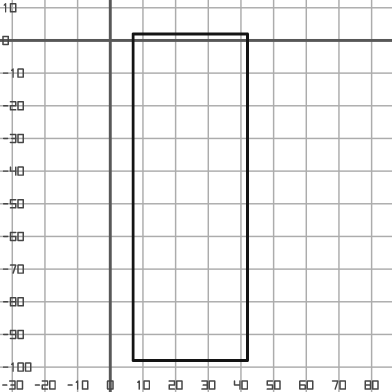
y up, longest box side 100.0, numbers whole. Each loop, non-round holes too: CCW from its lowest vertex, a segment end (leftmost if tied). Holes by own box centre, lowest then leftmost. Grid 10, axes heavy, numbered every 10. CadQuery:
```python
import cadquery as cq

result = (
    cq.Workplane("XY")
    .moveTo(7.0, -98.0)
    .lineTo(42.0, -98.0)
    .lineTo(42.0, 2.0)
    .lineTo(7.0, 2.0)
    .close()
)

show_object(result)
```